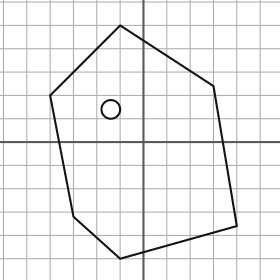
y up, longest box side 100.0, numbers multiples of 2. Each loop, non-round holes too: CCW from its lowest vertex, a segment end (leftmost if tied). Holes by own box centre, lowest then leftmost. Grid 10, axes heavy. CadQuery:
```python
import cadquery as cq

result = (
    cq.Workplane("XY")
    .moveTo(-10.0, -50.0)
    .lineTo(40.0, -36.0)
    .lineTo(30.0, 24.0)
    .lineTo(-10.0, 50.0)
    .lineTo(-40.0, 20.0)
    .lineTo(-30.0, -32.0)
    .close()
    .moveTo(-14.0, 14.0)
    .circle(4.0)
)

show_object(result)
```